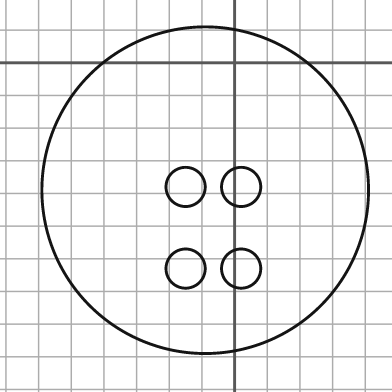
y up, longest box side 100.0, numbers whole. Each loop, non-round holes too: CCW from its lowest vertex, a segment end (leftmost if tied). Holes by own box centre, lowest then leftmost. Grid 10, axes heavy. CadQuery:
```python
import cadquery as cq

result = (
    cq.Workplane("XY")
    .moveTo(-9.0, -39.0)
    .circle(50.0)
    .moveTo(-15.0, -63.0)
    .circle(6.0)
    .moveTo(2.0, -63.0)
    .circle(6.0)
    .moveTo(-15.0, -38.0)
    .circle(6.0)
    .moveTo(2.0, -38.0)
    .circle(6.0)
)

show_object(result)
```